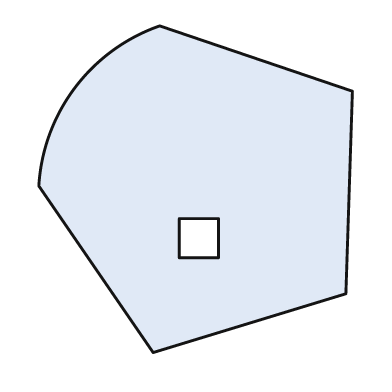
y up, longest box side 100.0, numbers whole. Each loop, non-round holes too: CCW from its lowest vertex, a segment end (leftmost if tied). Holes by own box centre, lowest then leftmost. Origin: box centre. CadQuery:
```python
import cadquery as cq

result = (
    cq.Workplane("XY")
    .moveTo(-13.0, -50.0)
    .lineTo(46.0, -32.0)
    .lineTo(48.0, 30.0)
    .lineTo(-11.0, 50.0)
    .threePointArc((-37.0, 31.0), (-48.0, 1.0))
    .close()
    .moveTo(-5.0, -21.0)
    .lineTo(7.0, -21.0)
    .lineTo(7.0, -9.0)
    .lineTo(-5.0, -9.0)
    .close()
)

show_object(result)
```